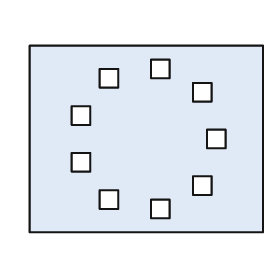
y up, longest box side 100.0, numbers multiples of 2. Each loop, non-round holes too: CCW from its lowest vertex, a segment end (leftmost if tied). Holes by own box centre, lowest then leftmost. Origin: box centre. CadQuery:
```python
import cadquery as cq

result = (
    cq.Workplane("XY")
    .moveTo(-50.0, -40.0)
    .lineTo(50.0, -40.0)
    .lineTo(50.0, 40.0)
    .lineTo(-50.0, 40.0)
    .close()
    .moveTo(2.0, -34.0)
    .lineTo(10.0, -34.0)
    .lineTo(10.0, -26.0)
    .lineTo(2.0, -26.0)
    .close()
    .moveTo(-20.0, -30.0)
    .lineTo(-12.0, -30.0)
    .lineTo(-12.0, -22.0)
    .lineTo(-20.0, -22.0)
    .close()
    .moveTo(20.0, -24.0)
    .lineTo(28.0, -24.0)
    .lineTo(28.0, -16.0)
    .lineTo(20.0, -16.0)
    .close()
    .moveTo(-32.0, -14.0)
    .lineTo(-24.0, -14.0)
    .lineTo(-24.0, -6.0)
    .lineTo(-32.0, -6.0)
    .close()
    .moveTo(26.0, -4.0)
    .lineTo(34.0, -4.0)
    .lineTo(34.0, 4.0)
    .lineTo(26.0, 4.0)
    .close()
    .moveTo(-32.0, 6.0)
    .lineTo(-24.0, 6.0)
    .lineTo(-24.0, 14.0)
    .lineTo(-32.0, 14.0)
    .close()
    .moveTo(20.0, 16.0)
    .lineTo(28.0, 16.0)
    .lineTo(28.0, 24.0)
    .lineTo(20.0, 24.0)
    .close()
    .moveTo(-20.0, 22.0)
    .lineTo(-12.0, 22.0)
    .lineTo(-12.0, 30.0)
    .lineTo(-20.0, 30.0)
    .close()
    .moveTo(2.0, 26.0)
    .lineTo(10.0, 26.0)
    .lineTo(10.0, 34.0)
    .lineTo(2.0, 34.0)
    .close()
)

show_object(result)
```